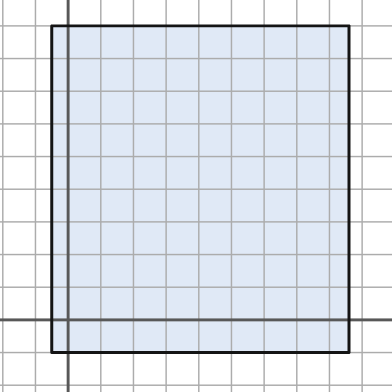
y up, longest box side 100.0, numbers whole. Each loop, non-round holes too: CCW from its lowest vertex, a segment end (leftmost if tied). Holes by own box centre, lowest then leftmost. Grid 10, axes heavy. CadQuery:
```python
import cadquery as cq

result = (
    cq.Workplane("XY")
    .moveTo(-5.0, -10.0)
    .lineTo(86.0, -10.0)
    .lineTo(86.0, 90.0)
    .lineTo(-5.0, 90.0)
    .close()
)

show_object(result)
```